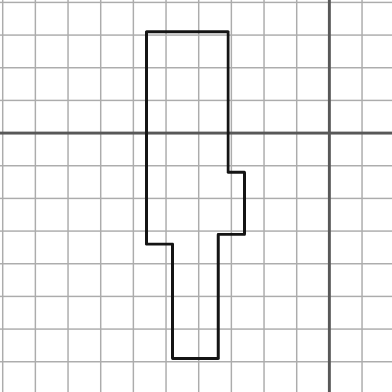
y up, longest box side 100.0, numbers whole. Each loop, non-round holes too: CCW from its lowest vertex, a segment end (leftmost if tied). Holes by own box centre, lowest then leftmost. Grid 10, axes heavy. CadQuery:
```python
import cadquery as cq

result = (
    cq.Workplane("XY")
    .moveTo(-48.0, -69.0)
    .lineTo(-34.0, -69.0)
    .lineTo(-34.0, -31.0)
    .lineTo(-26.0, -31.0)
    .lineTo(-26.0, -12.0)
    .lineTo(-31.0, -12.0)
    .lineTo(-31.0, 31.0)
    .lineTo(-56.0, 31.0)
    .lineTo(-56.0, -34.0)
    .lineTo(-48.0, -34.0)
    .close()
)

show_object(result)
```